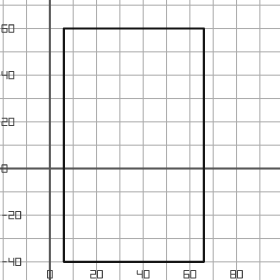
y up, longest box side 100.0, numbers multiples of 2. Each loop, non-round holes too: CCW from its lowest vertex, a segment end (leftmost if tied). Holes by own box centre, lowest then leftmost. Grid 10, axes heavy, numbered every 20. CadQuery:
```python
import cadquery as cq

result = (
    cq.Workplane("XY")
    .moveTo(6.0, -40.0)
    .lineTo(66.0, -40.0)
    .lineTo(66.0, 60.0)
    .lineTo(6.0, 60.0)
    .close()
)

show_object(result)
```